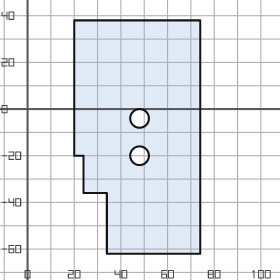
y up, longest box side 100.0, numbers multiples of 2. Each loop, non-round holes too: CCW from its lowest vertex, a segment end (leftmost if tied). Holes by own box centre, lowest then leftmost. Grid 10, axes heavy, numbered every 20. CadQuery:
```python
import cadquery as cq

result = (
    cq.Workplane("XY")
    .moveTo(34.0, -62.0)
    .lineTo(74.0, -62.0)
    .lineTo(74.0, 38.0)
    .lineTo(20.0, 38.0)
    .lineTo(20.0, -20.0)
    .lineTo(24.0, -20.0)
    .lineTo(24.0, -36.0)
    .lineTo(34.0, -36.0)
    .close()
    .moveTo(48.0, -20.0)
    .circle(4.0)
    .moveTo(48.0, -4.0)
    .circle(4.0)
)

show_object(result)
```